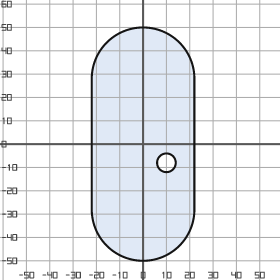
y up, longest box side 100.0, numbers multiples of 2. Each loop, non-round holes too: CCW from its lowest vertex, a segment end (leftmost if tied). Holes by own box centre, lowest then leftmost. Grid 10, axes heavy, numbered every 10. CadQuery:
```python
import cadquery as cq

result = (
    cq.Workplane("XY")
    .moveTo(-22.0, -28.0)
    .threePointArc((0.0, -50.0), (22.0, -28.0))
    .lineTo(22.0, 28.0)
    .threePointArc((0.0, 50.0), (-22.0, 28.0))
    .close()
    .moveTo(10.0, -8.0)
    .circle(4.0)
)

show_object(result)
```